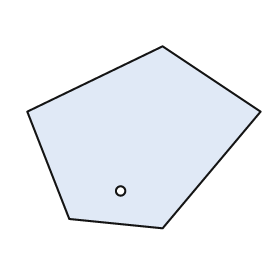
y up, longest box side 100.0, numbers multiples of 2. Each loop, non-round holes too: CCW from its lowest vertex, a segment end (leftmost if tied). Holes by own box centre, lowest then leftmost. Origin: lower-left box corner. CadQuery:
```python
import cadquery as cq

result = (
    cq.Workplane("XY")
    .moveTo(58.0, 0.0)
    .lineTo(100.0, 50.0)
    .lineTo(58.0, 78.0)
    .lineTo(0.0, 50.0)
    .lineTo(18.0, 4.0)
    .close()
    .moveTo(40.0, 16.0)
    .circle(2.0)
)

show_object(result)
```